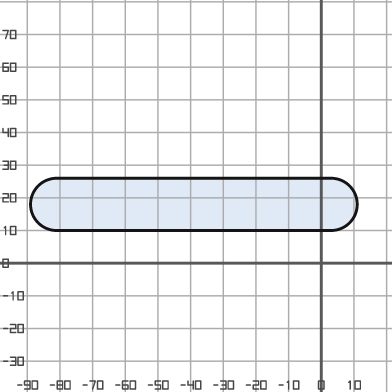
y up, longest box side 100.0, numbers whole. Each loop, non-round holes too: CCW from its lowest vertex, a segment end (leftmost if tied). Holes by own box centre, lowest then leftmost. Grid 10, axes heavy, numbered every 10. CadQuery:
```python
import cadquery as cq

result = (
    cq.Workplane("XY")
    .moveTo(-81.0, 10.0)
    .lineTo(3.0, 10.0)
    .threePointArc((11.0, 18.0), (3.0, 26.0))
    .lineTo(-81.0, 26.0)
    .threePointArc((-89.0, 18.0), (-81.0, 10.0))
    .close()
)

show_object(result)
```